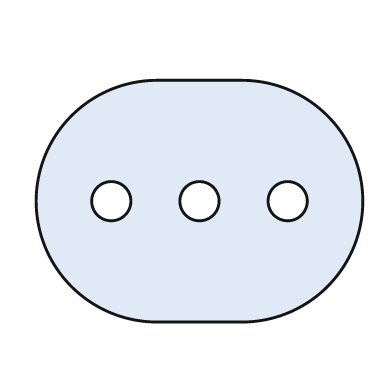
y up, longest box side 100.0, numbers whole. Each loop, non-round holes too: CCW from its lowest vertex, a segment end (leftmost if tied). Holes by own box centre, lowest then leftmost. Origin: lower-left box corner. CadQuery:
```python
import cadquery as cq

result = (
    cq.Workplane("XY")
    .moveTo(37.0, 0.0)
    .lineTo(63.0, 0.0)
    .threePointArc((100.0, 37.0), (63.0, 74.0))
    .lineTo(37.0, 74.0)
    .threePointArc((0.0, 37.0), (37.0, 0.0))
    .close()
    .moveTo(23.0, 37.0)
    .circle(6.0)
    .moveTo(50.0, 37.0)
    .circle(6.0)
    .moveTo(77.0, 37.0)
    .circle(6.0)
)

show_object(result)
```